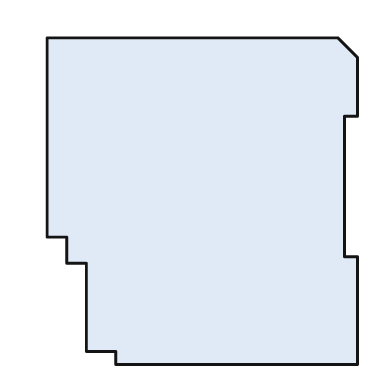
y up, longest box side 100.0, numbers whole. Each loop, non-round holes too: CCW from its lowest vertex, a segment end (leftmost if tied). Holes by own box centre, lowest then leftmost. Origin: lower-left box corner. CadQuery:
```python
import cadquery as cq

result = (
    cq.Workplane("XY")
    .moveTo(21.0, 0.0)
    .lineTo(95.0, 0.0)
    .lineTo(95.0, 33.0)
    .lineTo(91.0, 33.0)
    .lineTo(91.0, 76.0)
    .lineTo(95.0, 76.0)
    .lineTo(95.0, 94.0)
    .lineTo(89.0, 100.0)
    .lineTo(0.0, 100.0)
    .lineTo(0.0, 39.0)
    .lineTo(6.0, 39.0)
    .lineTo(6.0, 31.0)
    .lineTo(12.0, 31.0)
    .lineTo(12.0, 4.0)
    .lineTo(21.0, 4.0)
    .close()
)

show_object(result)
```